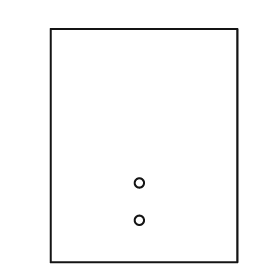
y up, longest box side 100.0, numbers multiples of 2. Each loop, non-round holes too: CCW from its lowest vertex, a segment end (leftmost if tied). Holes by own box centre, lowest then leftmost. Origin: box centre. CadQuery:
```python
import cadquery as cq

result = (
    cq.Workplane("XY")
    .moveTo(-40.0, -50.0)
    .lineTo(40.0, -50.0)
    .lineTo(40.0, 50.0)
    .lineTo(-40.0, 50.0)
    .close()
    .moveTo(-2.0, -32.0)
    .circle(2.0)
    .moveTo(-2.0, -16.0)
    .circle(2.0)
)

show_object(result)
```